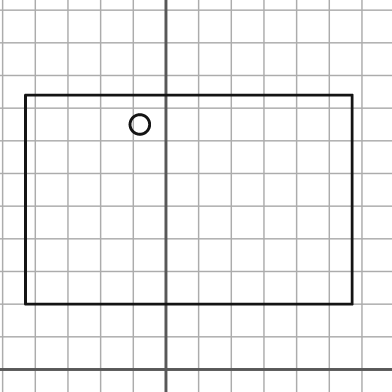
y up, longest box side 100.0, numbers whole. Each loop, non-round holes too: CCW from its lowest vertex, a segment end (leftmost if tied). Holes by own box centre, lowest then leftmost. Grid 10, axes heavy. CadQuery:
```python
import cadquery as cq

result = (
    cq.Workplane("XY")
    .moveTo(-43.0, 20.0)
    .lineTo(57.0, 20.0)
    .lineTo(57.0, 84.0)
    .lineTo(-43.0, 84.0)
    .close()
    .moveTo(-8.0, 75.0)
    .circle(3.0)
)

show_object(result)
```